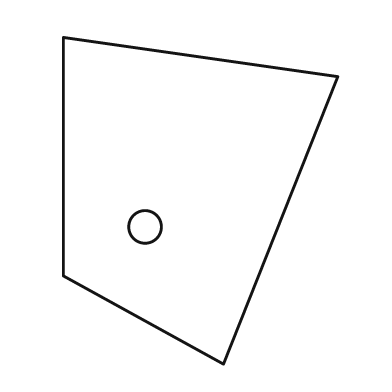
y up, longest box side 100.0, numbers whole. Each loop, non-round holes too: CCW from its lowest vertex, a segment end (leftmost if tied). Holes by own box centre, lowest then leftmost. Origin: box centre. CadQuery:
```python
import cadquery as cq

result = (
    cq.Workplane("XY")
    .moveTo(7.0, -50.0)
    .lineTo(42.0, 38.0)
    .lineTo(-42.0, 50.0)
    .lineTo(-42.0, -23.0)
    .close()
    .moveTo(-17.0, -8.0)
    .circle(5.0)
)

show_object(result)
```